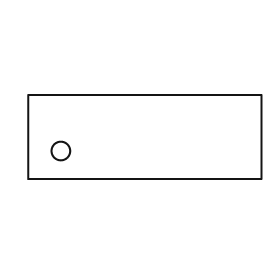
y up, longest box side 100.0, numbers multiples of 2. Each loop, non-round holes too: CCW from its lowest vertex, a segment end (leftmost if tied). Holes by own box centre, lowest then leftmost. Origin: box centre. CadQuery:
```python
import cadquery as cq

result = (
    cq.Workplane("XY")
    .moveTo(-50.0, -18.0)
    .lineTo(50.0, -18.0)
    .lineTo(50.0, 18.0)
    .lineTo(-50.0, 18.0)
    .close()
    .moveTo(-36.0, -6.0)
    .circle(4.0)
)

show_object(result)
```